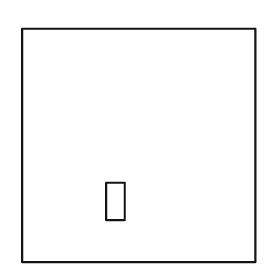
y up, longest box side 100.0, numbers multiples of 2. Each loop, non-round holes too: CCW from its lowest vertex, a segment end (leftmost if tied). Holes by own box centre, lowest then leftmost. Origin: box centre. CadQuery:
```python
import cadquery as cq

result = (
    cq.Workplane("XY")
    .moveTo(-50.0, -50.0)
    .lineTo(50.0, -50.0)
    .lineTo(50.0, 50.0)
    .lineTo(-50.0, 50.0)
    .close()
    .moveTo(-14.0, -32.0)
    .lineTo(-6.0, -32.0)
    .lineTo(-6.0, -16.0)
    .lineTo(-14.0, -16.0)
    .close()
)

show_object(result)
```